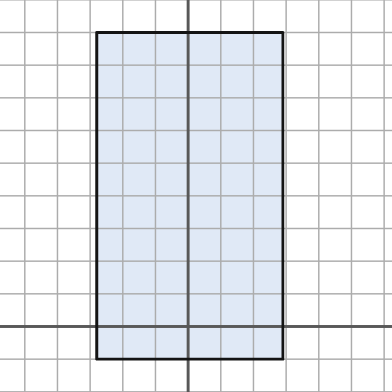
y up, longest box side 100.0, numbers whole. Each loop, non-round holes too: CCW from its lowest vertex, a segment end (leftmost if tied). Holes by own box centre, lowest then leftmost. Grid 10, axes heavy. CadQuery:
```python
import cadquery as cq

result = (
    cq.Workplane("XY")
    .moveTo(-28.0, -10.0)
    .lineTo(29.0, -10.0)
    .lineTo(29.0, 90.0)
    .lineTo(-28.0, 90.0)
    .close()
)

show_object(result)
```